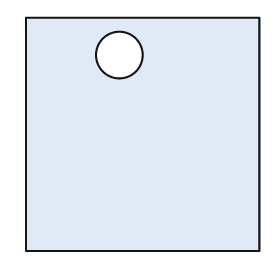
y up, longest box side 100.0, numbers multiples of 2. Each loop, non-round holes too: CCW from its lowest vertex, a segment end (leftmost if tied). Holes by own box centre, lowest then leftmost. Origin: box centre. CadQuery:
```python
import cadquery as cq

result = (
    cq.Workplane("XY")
    .moveTo(-50.0, -50.0)
    .lineTo(50.0, -50.0)
    .lineTo(50.0, 50.0)
    .lineTo(-50.0, 50.0)
    .close()
    .moveTo(-10.0, 34.0)
    .circle(10.0)
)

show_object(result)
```